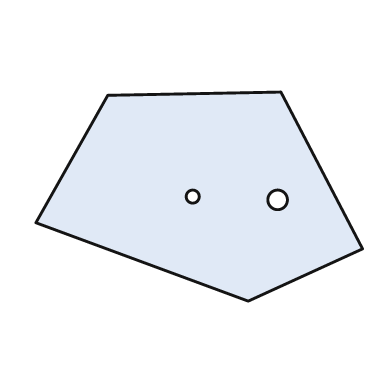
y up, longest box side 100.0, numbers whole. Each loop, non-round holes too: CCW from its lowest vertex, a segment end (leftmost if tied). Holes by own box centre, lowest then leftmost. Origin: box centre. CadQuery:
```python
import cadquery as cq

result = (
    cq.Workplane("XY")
    .moveTo(15.0, -32.0)
    .lineTo(50.0, -16.0)
    .lineTo(25.0, 32.0)
    .lineTo(-28.0, 31.0)
    .lineTo(-50.0, -8.0)
    .close()
    .moveTo(24.0, -1.0)
    .circle(3.0)
    .moveTo(-2.0, 0.0)
    .circle(2.0)
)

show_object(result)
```